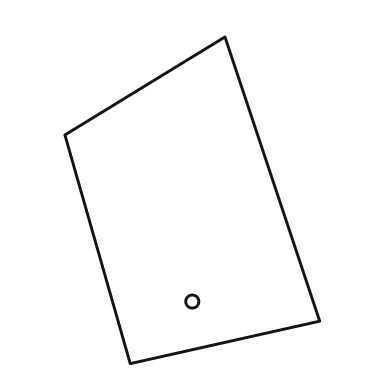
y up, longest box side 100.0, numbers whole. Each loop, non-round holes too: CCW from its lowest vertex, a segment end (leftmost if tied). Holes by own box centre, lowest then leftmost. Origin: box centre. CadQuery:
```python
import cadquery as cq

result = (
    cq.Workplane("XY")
    .moveTo(-19.0, -50.0)
    .lineTo(39.0, -37.0)
    .lineTo(10.0, 50.0)
    .lineTo(-39.0, 20.0)
    .close()
    .moveTo(0.0, -31.0)
    .circle(2.0)
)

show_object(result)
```